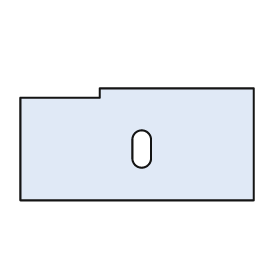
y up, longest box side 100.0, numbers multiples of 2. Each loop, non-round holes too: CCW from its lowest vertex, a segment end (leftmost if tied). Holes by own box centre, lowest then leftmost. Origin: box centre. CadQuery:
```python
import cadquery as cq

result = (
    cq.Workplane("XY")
    .moveTo(-50.0, -24.0)
    .lineTo(50.0, -24.0)
    .lineTo(50.0, 24.0)
    .lineTo(-16.0, 24.0)
    .lineTo(-16.0, 20.0)
    .lineTo(-50.0, 20.0)
    .close()
    .moveTo(-2.0, -6.0)
    .threePointArc((2.0, -10.0), (6.0, -6.0))
    .lineTo(6.0, 2.0)
    .threePointArc((2.0, 6.0), (-2.0, 2.0))
    .close()
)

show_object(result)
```